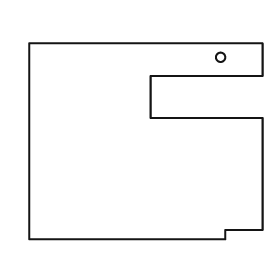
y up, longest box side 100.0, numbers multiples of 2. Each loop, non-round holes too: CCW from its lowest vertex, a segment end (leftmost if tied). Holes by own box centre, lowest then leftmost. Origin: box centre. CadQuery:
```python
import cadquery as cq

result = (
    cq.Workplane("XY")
    .moveTo(-50.0, -42.0)
    .lineTo(34.0, -42.0)
    .lineTo(34.0, -38.0)
    .lineTo(50.0, -38.0)
    .lineTo(50.0, 10.0)
    .lineTo(2.0, 10.0)
    .lineTo(2.0, 28.0)
    .lineTo(50.0, 28.0)
    .lineTo(50.0, 42.0)
    .lineTo(-50.0, 42.0)
    .close()
    .moveTo(32.0, 36.0)
    .circle(2.0)
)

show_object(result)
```